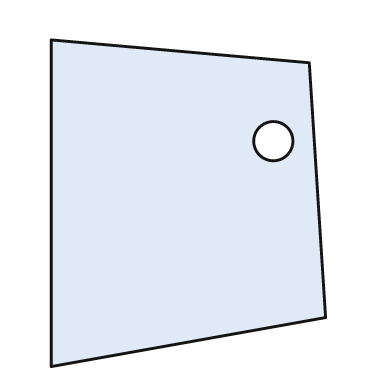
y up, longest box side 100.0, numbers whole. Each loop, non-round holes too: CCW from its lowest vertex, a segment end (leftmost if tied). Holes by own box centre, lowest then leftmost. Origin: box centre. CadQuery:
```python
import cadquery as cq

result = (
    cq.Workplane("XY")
    .moveTo(-42.0, -50.0)
    .lineTo(42.0, -35.0)
    .lineTo(37.0, 43.0)
    .lineTo(-42.0, 50.0)
    .close()
    .moveTo(26.0, 19.0)
    .circle(6.0)
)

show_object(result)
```